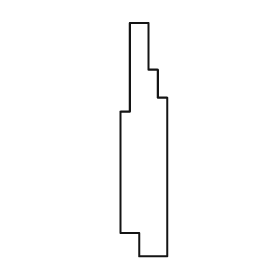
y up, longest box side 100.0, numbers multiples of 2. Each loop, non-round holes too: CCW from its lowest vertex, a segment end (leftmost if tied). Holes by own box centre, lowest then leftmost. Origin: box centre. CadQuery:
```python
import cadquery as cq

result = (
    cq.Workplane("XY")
    .moveTo(-2.0, -50.0)
    .lineTo(10.0, -50.0)
    .lineTo(10.0, 18.0)
    .lineTo(6.0, 18.0)
    .lineTo(6.0, 30.0)
    .lineTo(2.0, 30.0)
    .lineTo(2.0, 50.0)
    .lineTo(-6.0, 50.0)
    .lineTo(-6.0, 12.0)
    .lineTo(-10.0, 12.0)
    .lineTo(-10.0, -40.0)
    .lineTo(-2.0, -40.0)
    .close()
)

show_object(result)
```